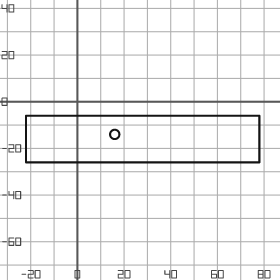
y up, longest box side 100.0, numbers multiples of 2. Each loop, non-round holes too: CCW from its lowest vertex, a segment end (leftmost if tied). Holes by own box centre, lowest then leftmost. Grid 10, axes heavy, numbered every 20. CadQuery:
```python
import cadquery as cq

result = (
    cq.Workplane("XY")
    .moveTo(-22.0, -26.0)
    .lineTo(78.0, -26.0)
    .lineTo(78.0, -6.0)
    .lineTo(-22.0, -6.0)
    .close()
    .moveTo(16.0, -14.0)
    .circle(2.0)
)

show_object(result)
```